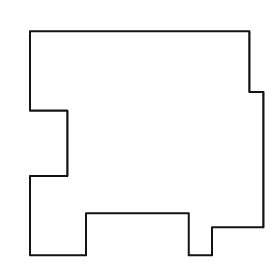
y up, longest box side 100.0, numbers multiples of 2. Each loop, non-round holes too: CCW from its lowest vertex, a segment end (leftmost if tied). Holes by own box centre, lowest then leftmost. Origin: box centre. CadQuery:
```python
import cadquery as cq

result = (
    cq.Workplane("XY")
    .moveTo(-50.0, -48.0)
    .lineTo(-26.0, -48.0)
    .lineTo(-26.0, -30.0)
    .lineTo(18.0, -30.0)
    .lineTo(18.0, -48.0)
    .lineTo(28.0, -48.0)
    .lineTo(28.0, -36.0)
    .lineTo(50.0, -36.0)
    .lineTo(50.0, 22.0)
    .lineTo(44.0, 22.0)
    .lineTo(44.0, 48.0)
    .lineTo(-50.0, 48.0)
    .lineTo(-50.0, 14.0)
    .lineTo(-34.0, 14.0)
    .lineTo(-34.0, -14.0)
    .lineTo(-50.0, -14.0)
    .close()
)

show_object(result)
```